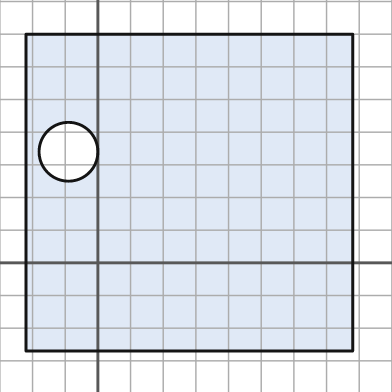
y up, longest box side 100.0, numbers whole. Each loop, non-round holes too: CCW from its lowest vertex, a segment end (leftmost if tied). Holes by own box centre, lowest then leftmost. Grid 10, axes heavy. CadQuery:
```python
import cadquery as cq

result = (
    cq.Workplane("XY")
    .moveTo(-22.0, -27.0)
    .lineTo(78.0, -27.0)
    .lineTo(78.0, 70.0)
    .lineTo(-22.0, 70.0)
    .close()
    .moveTo(-9.0, 34.0)
    .circle(9.0)
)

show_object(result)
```